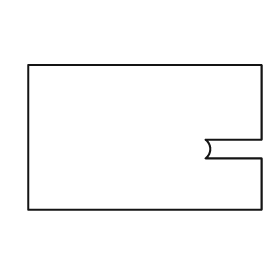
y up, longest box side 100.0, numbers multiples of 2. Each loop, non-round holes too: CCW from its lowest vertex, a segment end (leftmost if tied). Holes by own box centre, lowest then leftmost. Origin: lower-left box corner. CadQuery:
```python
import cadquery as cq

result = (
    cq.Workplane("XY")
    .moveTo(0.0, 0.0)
    .lineTo(100.0, 0.0)
    .lineTo(100.0, 22.0)
    .lineTo(76.0, 22.0)
    .threePointArc((78.0, 26.0), (76.0, 30.0))
    .lineTo(100.0, 30.0)
    .lineTo(100.0, 62.0)
    .lineTo(0.0, 62.0)
    .close()
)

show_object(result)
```